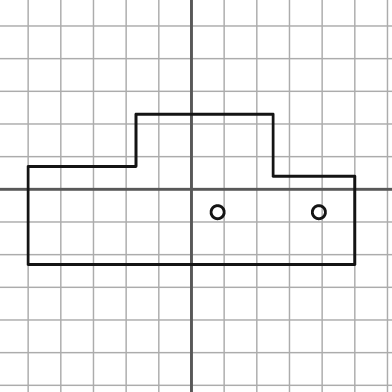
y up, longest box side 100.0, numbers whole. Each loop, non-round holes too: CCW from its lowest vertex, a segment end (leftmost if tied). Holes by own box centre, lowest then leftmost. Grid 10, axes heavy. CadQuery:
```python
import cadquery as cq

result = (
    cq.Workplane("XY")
    .moveTo(-50.0, -23.0)
    .lineTo(50.0, -23.0)
    .lineTo(50.0, 4.0)
    .lineTo(25.0, 4.0)
    .lineTo(25.0, 23.0)
    .lineTo(-17.0, 23.0)
    .lineTo(-17.0, 7.0)
    .lineTo(-50.0, 7.0)
    .close()
    .moveTo(8.0, -7.0)
    .circle(2.0)
    .moveTo(39.0, -7.0)
    .circle(2.0)
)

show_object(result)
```